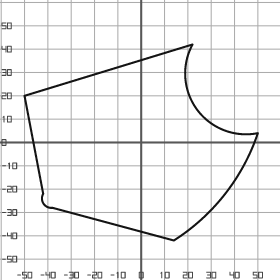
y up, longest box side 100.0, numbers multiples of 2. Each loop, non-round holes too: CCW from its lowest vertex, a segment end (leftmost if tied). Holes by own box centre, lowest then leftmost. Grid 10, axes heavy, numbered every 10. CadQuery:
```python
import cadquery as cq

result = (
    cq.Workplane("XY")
    .moveTo(14.0, -42.0)
    .threePointArc((36.0, -22.0), (50.0, 4.0))
    .threePointArc((24.0, 14.0), (22.0, 42.0))
    .lineTo(-50.0, 20.0)
    .lineTo(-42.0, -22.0)
    .threePointArc((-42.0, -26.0), (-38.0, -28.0))
    .close()
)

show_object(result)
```